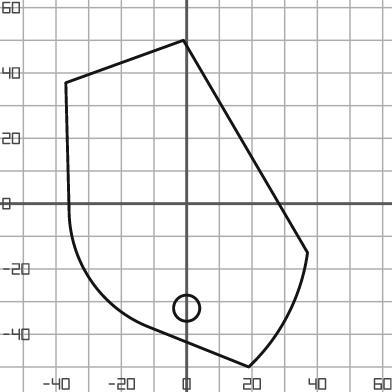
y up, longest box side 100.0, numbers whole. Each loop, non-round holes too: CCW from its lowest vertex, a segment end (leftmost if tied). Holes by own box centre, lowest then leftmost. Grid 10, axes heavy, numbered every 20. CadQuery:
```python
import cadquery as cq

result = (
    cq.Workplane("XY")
    .moveTo(19.0, -50.0)
    .threePointArc((31.0, -34.0), (37.0, -15.0))
    .lineTo(-1.0, 50.0)
    .lineTo(-37.0, 37.0)
    .lineTo(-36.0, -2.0)
    .threePointArc((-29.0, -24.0), (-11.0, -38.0))
    .close()
    .moveTo(0.0, -32.0)
    .circle(4.0)
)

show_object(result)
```